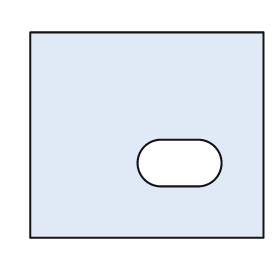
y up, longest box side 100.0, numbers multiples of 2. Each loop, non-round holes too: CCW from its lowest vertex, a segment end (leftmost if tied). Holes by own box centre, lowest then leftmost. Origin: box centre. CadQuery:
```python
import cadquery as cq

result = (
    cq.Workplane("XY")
    .moveTo(-50.0, -44.0)
    .lineTo(50.0, -44.0)
    .lineTo(50.0, 44.0)
    .lineTo(-50.0, 44.0)
    .close()
    .moveTo(6.0, -22.0)
    .lineTo(22.0, -22.0)
    .threePointArc((32.0, -12.0), (22.0, -2.0))
    .lineTo(6.0, -2.0)
    .threePointArc((-4.0, -12.0), (6.0, -22.0))
    .close()
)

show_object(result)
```